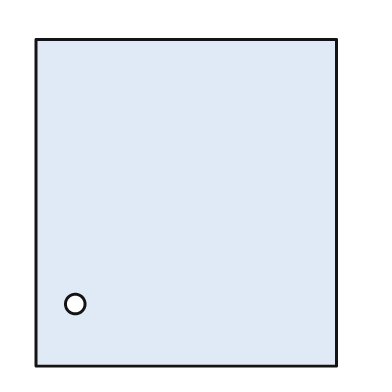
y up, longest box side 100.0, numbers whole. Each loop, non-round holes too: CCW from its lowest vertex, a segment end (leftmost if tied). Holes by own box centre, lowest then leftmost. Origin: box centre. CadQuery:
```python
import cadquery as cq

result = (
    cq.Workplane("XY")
    .moveTo(-46.0, -50.0)
    .lineTo(46.0, -50.0)
    .lineTo(46.0, 50.0)
    .lineTo(-46.0, 50.0)
    .close()
    .moveTo(-34.0, -31.0)
    .circle(3.0)
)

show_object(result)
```